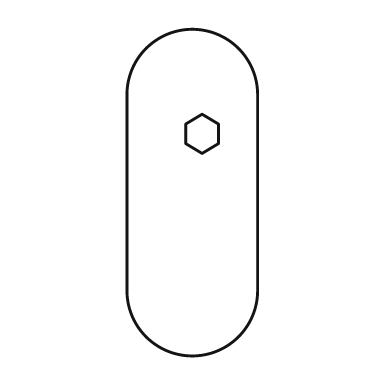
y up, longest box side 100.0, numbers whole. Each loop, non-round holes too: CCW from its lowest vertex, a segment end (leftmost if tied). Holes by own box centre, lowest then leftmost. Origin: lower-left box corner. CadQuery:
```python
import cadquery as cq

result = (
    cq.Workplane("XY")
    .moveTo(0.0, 20.0)
    .threePointArc((20.0, 0.0), (40.0, 20.0))
    .lineTo(40.0, 80.0)
    .threePointArc((20.0, 100.0), (0.0, 80.0))
    .close()
    .moveTo(23.0, 62.0)
    .lineTo(28.0, 65.0)
    .lineTo(28.0, 71.0)
    .lineTo(23.0, 74.0)
    .lineTo(18.0, 71.0)
    .lineTo(18.0, 65.0)
    .close()
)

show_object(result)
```